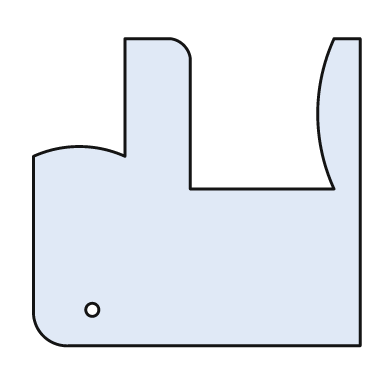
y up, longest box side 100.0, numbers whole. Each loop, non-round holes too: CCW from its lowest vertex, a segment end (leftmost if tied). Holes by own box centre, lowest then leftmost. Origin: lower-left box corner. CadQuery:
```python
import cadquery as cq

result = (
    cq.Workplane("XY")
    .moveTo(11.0, 0.0)
    .lineTo(100.0, 0.0)
    .lineTo(100.0, 94.0)
    .lineTo(92.0, 94.0)
    .threePointArc((87.0, 71.0), (92.0, 48.0))
    .lineTo(48.0, 48.0)
    .lineTo(48.0, 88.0)
    .threePointArc((46.0, 92.0), (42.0, 94.0))
    .lineTo(28.0, 94.0)
    .lineTo(28.0, 58.0)
    .threePointArc((14.0, 61.0), (0.0, 58.0))
    .lineTo(0.0, 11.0)
    .threePointArc((3.0, 3.0), (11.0, 0.0))
    .close()
    .moveTo(18.0, 11.0)
    .circle(2.0)
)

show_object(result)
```